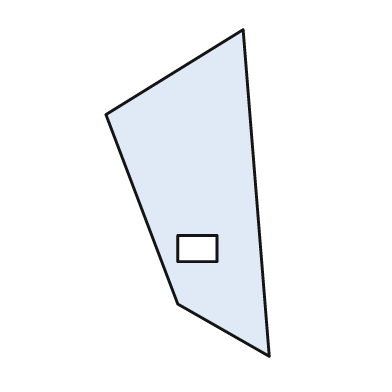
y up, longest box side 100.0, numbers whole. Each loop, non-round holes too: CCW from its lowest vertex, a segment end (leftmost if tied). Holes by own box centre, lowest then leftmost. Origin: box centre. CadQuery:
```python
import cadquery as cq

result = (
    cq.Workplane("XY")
    .moveTo(25.0, -50.0)
    .lineTo(17.0, 50.0)
    .lineTo(-25.0, 24.0)
    .lineTo(-3.0, -34.0)
    .close()
    .moveTo(-3.0, -21.0)
    .lineTo(9.0, -21.0)
    .lineTo(9.0, -13.0)
    .lineTo(-3.0, -13.0)
    .close()
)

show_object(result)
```